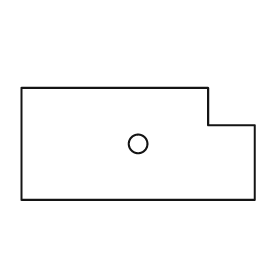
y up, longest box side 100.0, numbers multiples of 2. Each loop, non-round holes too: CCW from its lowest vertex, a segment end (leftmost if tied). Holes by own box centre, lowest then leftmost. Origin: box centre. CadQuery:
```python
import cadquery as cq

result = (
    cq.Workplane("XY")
    .moveTo(-50.0, -24.0)
    .lineTo(50.0, -24.0)
    .lineTo(50.0, 8.0)
    .lineTo(30.0, 8.0)
    .lineTo(30.0, 24.0)
    .lineTo(-50.0, 24.0)
    .close()
    .moveTo(0.0, 0.0)
    .circle(4.0)
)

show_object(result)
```